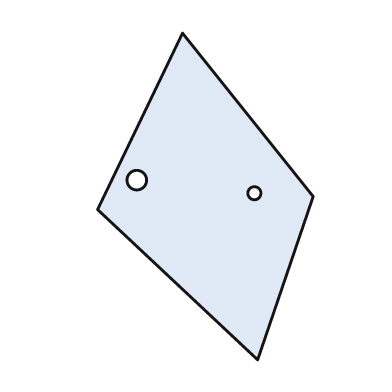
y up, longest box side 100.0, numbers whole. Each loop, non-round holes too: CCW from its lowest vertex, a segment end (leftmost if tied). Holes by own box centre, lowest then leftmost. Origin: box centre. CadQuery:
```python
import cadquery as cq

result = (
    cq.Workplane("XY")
    .moveTo(16.0, -50.0)
    .lineTo(33.0, 0.0)
    .lineTo(-7.0, 50.0)
    .lineTo(-33.0, -4.0)
    .close()
    .moveTo(15.0, 1.0)
    .circle(2.0)
    .moveTo(-21.0, 5.0)
    .circle(3.0)
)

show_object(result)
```